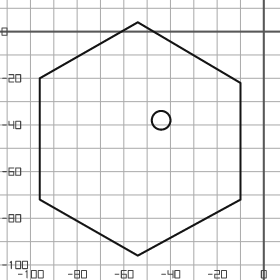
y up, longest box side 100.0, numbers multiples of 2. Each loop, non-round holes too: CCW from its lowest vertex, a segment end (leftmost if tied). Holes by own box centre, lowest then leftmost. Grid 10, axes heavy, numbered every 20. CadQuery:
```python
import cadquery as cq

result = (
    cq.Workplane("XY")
    .moveTo(-54.0, -96.0)
    .lineTo(-10.0, -72.0)
    .lineTo(-10.0, -22.0)
    .lineTo(-54.0, 4.0)
    .lineTo(-96.0, -20.0)
    .lineTo(-96.0, -72.0)
    .close()
    .moveTo(-44.0, -38.0)
    .circle(4.0)
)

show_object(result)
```